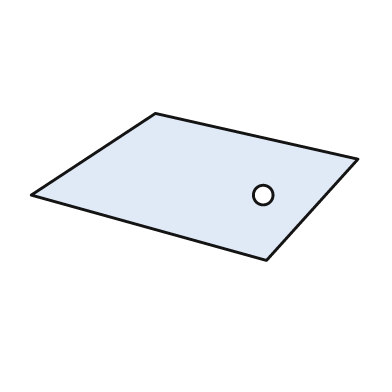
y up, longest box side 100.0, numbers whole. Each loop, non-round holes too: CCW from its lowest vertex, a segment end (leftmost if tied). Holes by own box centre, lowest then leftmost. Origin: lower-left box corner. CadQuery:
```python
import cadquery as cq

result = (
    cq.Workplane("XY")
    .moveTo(72.0, 0.0)
    .lineTo(100.0, 31.0)
    .lineTo(38.0, 45.0)
    .lineTo(0.0, 20.0)
    .close()
    .moveTo(71.0, 20.0)
    .circle(3.0)
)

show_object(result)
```